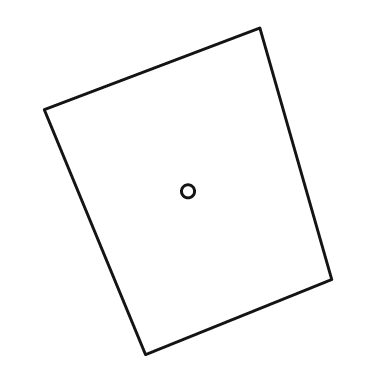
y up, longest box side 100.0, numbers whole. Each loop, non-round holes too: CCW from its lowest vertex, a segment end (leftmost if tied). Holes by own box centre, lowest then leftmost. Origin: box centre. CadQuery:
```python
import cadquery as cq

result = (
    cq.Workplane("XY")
    .moveTo(-13.0, -50.0)
    .lineTo(44.0, -27.0)
    .lineTo(22.0, 50.0)
    .lineTo(-44.0, 25.0)
    .close()
    .moveTo(0.0, 0.0)
    .circle(2.0)
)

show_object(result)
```